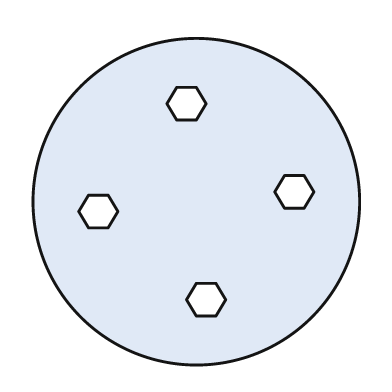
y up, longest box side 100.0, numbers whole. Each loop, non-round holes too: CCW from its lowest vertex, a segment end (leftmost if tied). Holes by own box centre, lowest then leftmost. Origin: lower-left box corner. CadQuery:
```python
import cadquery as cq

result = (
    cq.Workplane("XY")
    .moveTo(50.0, 50.0)
    .circle(50.0)
    .moveTo(50.0, 15.0)
    .lineTo(56.0, 15.0)
    .lineTo(59.0, 20.0)
    .lineTo(56.0, 25.0)
    .lineTo(50.0, 25.0)
    .lineTo(47.0, 20.0)
    .close()
    .moveTo(17.0, 42.0)
    .lineTo(23.0, 42.0)
    .lineTo(26.0, 47.0)
    .lineTo(23.0, 52.0)
    .lineTo(17.0, 52.0)
    .lineTo(14.0, 47.0)
    .close()
    .moveTo(77.0, 48.0)
    .lineTo(83.0, 48.0)
    .lineTo(86.0, 53.0)
    .lineTo(83.0, 58.0)
    .lineTo(77.0, 58.0)
    .lineTo(74.0, 53.0)
    .close()
    .moveTo(44.0, 75.0)
    .lineTo(50.0, 75.0)
    .lineTo(53.0, 80.0)
    .lineTo(50.0, 85.0)
    .lineTo(44.0, 85.0)
    .lineTo(41.0, 80.0)
    .close()
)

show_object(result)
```